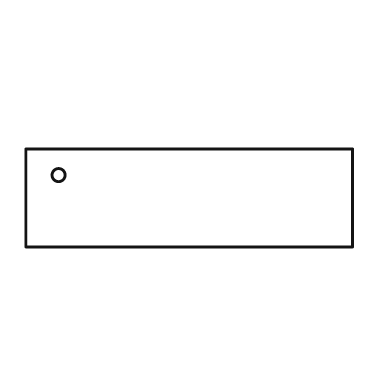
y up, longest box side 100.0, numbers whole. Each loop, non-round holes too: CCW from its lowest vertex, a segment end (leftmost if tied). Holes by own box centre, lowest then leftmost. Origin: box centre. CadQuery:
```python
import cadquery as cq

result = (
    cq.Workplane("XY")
    .moveTo(-50.0, -15.0)
    .lineTo(50.0, -15.0)
    .lineTo(50.0, 15.0)
    .lineTo(-50.0, 15.0)
    .close()
    .moveTo(-40.0, 7.0)
    .circle(2.0)
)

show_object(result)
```